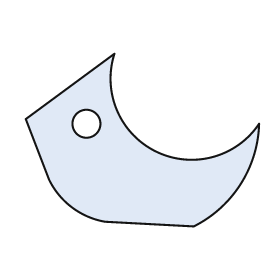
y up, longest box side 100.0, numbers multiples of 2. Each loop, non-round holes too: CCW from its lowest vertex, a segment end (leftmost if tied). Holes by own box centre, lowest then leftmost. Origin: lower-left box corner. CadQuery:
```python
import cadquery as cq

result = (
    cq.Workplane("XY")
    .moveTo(72.0, 0.0)
    .threePointArc((92.0, 18.0), (100.0, 44.0))
    .threePointArc((56.0, 32.0), (38.0, 74.0))
    .lineTo(0.0, 46.0)
    .lineTo(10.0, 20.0)
    .threePointArc((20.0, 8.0), (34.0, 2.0))
    .close()
    .moveTo(26.0, 44.0)
    .circle(6.0)
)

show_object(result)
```